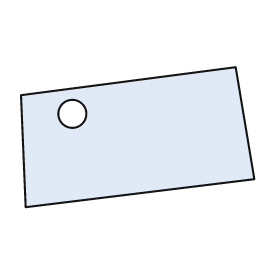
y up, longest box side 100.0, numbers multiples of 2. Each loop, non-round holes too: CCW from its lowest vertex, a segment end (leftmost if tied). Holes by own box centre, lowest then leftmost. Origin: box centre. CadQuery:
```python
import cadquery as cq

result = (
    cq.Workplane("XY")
    .moveTo(-48.0, -30.0)
    .lineTo(50.0, -18.0)
    .lineTo(42.0, 30.0)
    .lineTo(-50.0, 18.0)
    .close()
    .moveTo(-28.0, 10.0)
    .circle(6.0)
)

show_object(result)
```